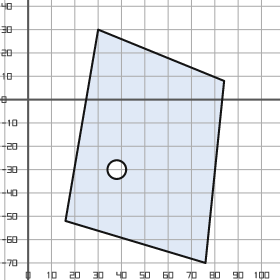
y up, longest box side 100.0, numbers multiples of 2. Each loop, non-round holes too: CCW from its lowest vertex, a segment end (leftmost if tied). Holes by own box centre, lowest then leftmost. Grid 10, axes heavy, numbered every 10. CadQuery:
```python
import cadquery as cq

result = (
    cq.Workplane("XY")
    .moveTo(76.0, -70.0)
    .lineTo(84.0, 8.0)
    .lineTo(30.0, 30.0)
    .lineTo(16.0, -52.0)
    .close()
    .moveTo(38.0, -30.0)
    .circle(4.0)
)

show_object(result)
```